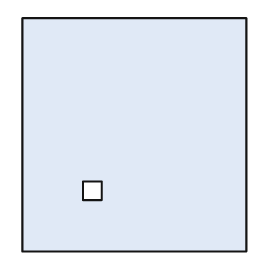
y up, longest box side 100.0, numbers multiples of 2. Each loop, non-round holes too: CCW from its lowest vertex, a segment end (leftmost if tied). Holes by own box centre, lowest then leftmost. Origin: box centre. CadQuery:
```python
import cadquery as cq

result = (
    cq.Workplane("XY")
    .moveTo(-48.0, -50.0)
    .lineTo(48.0, -50.0)
    .lineTo(48.0, 50.0)
    .lineTo(-48.0, 50.0)
    .close()
    .moveTo(-22.0, -28.0)
    .lineTo(-14.0, -28.0)
    .lineTo(-14.0, -20.0)
    .lineTo(-22.0, -20.0)
    .close()
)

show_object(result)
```